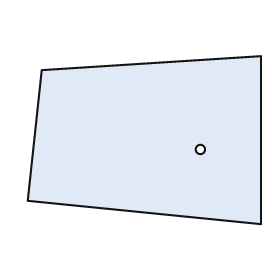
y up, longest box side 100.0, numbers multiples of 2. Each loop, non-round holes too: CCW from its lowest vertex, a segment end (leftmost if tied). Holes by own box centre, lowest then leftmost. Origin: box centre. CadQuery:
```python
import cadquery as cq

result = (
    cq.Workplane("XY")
    .moveTo(50.0, -36.0)
    .lineTo(50.0, 36.0)
    .lineTo(-44.0, 30.0)
    .lineTo(-50.0, -26.0)
    .close()
    .moveTo(24.0, -4.0)
    .circle(2.0)
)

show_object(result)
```